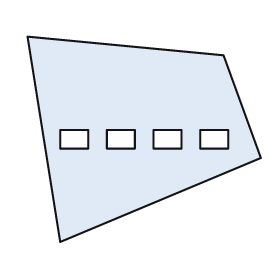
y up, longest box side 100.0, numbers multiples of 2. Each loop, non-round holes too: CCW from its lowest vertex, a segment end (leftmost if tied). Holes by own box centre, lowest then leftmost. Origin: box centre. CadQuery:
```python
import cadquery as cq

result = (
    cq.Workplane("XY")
    .moveTo(-36.0, -44.0)
    .lineTo(50.0, -8.0)
    .lineTo(34.0, 36.0)
    .lineTo(-50.0, 44.0)
    .close()
    .moveTo(-36.0, -4.0)
    .lineTo(-24.0, -4.0)
    .lineTo(-24.0, 4.0)
    .lineTo(-36.0, 4.0)
    .close()
    .moveTo(-16.0, -4.0)
    .lineTo(-4.0, -4.0)
    .lineTo(-4.0, 4.0)
    .lineTo(-16.0, 4.0)
    .close()
    .moveTo(4.0, -4.0)
    .lineTo(16.0, -4.0)
    .lineTo(16.0, 4.0)
    .lineTo(4.0, 4.0)
    .close()
    .moveTo(24.0, -4.0)
    .lineTo(36.0, -4.0)
    .lineTo(36.0, 4.0)
    .lineTo(24.0, 4.0)
    .close()
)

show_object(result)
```